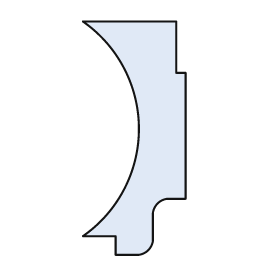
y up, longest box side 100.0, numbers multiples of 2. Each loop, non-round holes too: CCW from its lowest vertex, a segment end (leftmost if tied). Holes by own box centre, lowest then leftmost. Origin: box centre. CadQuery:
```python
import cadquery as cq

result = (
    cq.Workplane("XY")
    .moveTo(-8.0, -50.0)
    .lineTo(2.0, -50.0)
    .threePointArc((6.0, -48.0), (8.0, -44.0))
    .lineTo(8.0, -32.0)
    .threePointArc((10.0, -28.0), (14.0, -26.0))
    .lineTo(22.0, -26.0)
    .lineTo(22.0, 28.0)
    .lineTo(18.0, 28.0)
    .lineTo(18.0, 50.0)
    .lineTo(-22.0, 50.0)
    .threePointArc((2.0, 4.0), (-22.0, -42.0))
    .lineTo(-8.0, -42.0)
    .close()
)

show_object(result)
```